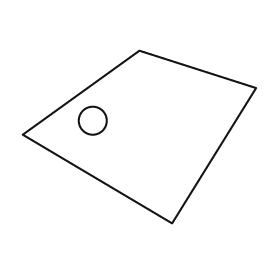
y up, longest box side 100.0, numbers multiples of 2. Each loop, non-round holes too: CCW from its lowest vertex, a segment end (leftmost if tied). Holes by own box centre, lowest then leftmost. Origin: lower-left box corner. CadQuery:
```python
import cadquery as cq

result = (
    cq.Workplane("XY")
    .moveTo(64.0, 0.0)
    .lineTo(100.0, 58.0)
    .lineTo(50.0, 74.0)
    .lineTo(0.0, 38.0)
    .close()
    .moveTo(30.0, 44.0)
    .circle(6.0)
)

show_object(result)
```